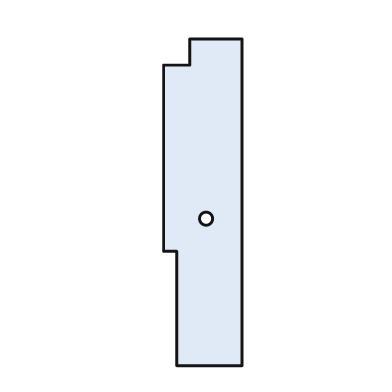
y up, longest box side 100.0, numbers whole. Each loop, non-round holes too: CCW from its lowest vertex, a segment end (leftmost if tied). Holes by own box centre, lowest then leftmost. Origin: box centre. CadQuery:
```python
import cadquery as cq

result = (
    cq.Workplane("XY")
    .moveTo(-8.0, -50.0)
    .lineTo(12.0, -50.0)
    .lineTo(12.0, 50.0)
    .lineTo(-4.0, 50.0)
    .lineTo(-4.0, 42.0)
    .lineTo(-12.0, 42.0)
    .lineTo(-12.0, -15.0)
    .lineTo(-8.0, -15.0)
    .close()
    .moveTo(1.0, -5.0)
    .circle(2.0)
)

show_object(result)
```